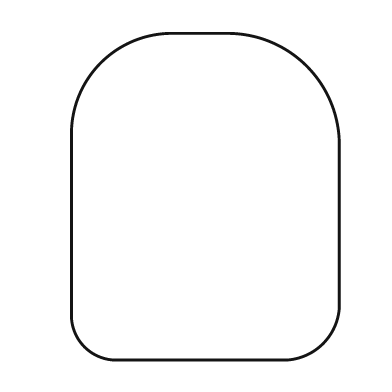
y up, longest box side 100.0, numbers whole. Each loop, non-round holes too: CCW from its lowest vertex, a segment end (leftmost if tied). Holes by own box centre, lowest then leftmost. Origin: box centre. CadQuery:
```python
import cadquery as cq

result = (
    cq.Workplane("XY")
    .moveTo(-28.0, -50.0)
    .lineTo(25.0, -50.0)
    .threePointArc((36.0, -45.0), (41.0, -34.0))
    .lineTo(41.0, 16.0)
    .threePointArc((31.0, 40.0), (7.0, 50.0))
    .lineTo(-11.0, 50.0)
    .threePointArc((-32.0, 41.0), (-41.0, 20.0))
    .lineTo(-41.0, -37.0)
    .threePointArc((-37.0, -46.0), (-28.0, -50.0))
    .close()
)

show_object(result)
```